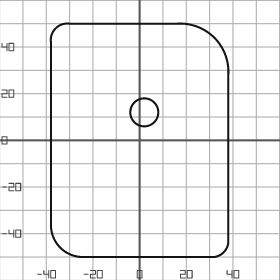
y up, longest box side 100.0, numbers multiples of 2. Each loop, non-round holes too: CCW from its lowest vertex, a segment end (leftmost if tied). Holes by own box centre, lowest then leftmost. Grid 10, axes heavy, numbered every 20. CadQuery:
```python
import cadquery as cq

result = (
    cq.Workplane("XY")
    .moveTo(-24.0, -50.0)
    .lineTo(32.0, -50.0)
    .threePointArc((36.0, -48.0), (38.0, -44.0))
    .lineTo(38.0, 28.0)
    .threePointArc((32.0, 44.0), (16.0, 50.0))
    .lineTo(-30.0, 50.0)
    .threePointArc((-36.0, 48.0), (-38.0, 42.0))
    .lineTo(-38.0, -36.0)
    .threePointArc((-34.0, -46.0), (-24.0, -50.0))
    .close()
    .moveTo(2.0, 12.0)
    .circle(6.0)
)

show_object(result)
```